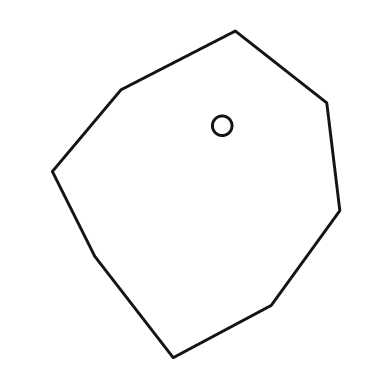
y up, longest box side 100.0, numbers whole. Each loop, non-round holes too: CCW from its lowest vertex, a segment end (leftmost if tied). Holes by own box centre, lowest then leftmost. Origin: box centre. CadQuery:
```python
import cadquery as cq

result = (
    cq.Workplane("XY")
    .moveTo(-7.0, -50.0)
    .lineTo(23.0, -34.0)
    .lineTo(44.0, -5.0)
    .lineTo(40.0, 28.0)
    .lineTo(12.0, 50.0)
    .lineTo(-23.0, 32.0)
    .lineTo(-44.0, 7.0)
    .lineTo(-31.0, -19.0)
    .close()
    .moveTo(8.0, 21.0)
    .circle(3.0)
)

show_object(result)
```